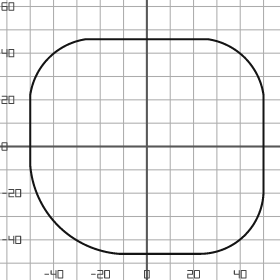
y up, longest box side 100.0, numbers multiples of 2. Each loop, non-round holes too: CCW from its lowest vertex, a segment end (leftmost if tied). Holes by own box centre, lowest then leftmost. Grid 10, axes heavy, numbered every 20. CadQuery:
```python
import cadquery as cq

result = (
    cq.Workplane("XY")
    .moveTo(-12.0, -46.0)
    .lineTo(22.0, -46.0)
    .threePointArc((42.0, -38.0), (50.0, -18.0))
    .lineTo(50.0, 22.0)
    .threePointArc((42.0, 38.0), (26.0, 46.0))
    .lineTo(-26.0, 46.0)
    .threePointArc((-42.0, 38.0), (-50.0, 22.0))
    .lineTo(-50.0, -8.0)
    .threePointArc((-38.0, -34.0), (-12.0, -46.0))
    .close()
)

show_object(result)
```